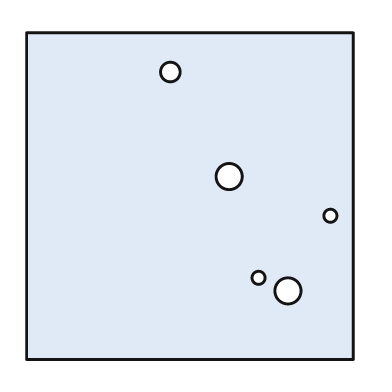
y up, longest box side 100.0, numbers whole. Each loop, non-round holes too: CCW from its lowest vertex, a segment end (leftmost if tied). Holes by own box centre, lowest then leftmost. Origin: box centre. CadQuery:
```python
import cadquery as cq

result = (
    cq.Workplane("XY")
    .moveTo(-50.0, -50.0)
    .lineTo(50.0, -50.0)
    .lineTo(50.0, 50.0)
    .lineTo(-50.0, 50.0)
    .close()
    .moveTo(30.0, -29.0)
    .circle(4.0)
    .moveTo(21.0, -25.0)
    .circle(2.0)
    .moveTo(43.0, -6.0)
    .circle(2.0)
    .moveTo(12.0, 6.0)
    .circle(4.0)
    .moveTo(-6.0, 38.0)
    .circle(3.0)
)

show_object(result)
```